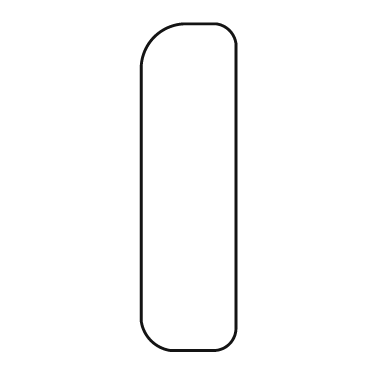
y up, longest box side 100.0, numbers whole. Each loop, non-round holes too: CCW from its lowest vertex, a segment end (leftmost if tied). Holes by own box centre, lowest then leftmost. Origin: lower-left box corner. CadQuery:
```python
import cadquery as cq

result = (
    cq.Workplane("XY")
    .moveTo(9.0, 0.0)
    .lineTo(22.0, 0.0)
    .threePointArc((27.0, 2.0), (29.0, 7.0))
    .lineTo(29.0, 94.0)
    .threePointArc((27.0, 98.0), (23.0, 100.0))
    .lineTo(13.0, 100.0)
    .threePointArc((4.0, 96.0), (0.0, 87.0))
    .lineTo(0.0, 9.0)
    .threePointArc((3.0, 3.0), (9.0, 0.0))
    .close()
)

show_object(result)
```